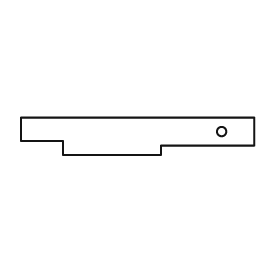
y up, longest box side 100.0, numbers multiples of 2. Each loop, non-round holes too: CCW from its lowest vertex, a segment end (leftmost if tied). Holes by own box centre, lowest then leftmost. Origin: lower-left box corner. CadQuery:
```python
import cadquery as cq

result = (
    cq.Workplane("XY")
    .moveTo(18.0, 0.0)
    .lineTo(60.0, 0.0)
    .lineTo(60.0, 4.0)
    .lineTo(100.0, 4.0)
    .lineTo(100.0, 16.0)
    .lineTo(0.0, 16.0)
    .lineTo(0.0, 6.0)
    .lineTo(18.0, 6.0)
    .close()
    .moveTo(86.0, 10.0)
    .circle(2.0)
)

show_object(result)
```